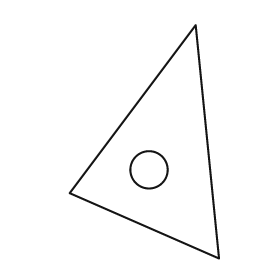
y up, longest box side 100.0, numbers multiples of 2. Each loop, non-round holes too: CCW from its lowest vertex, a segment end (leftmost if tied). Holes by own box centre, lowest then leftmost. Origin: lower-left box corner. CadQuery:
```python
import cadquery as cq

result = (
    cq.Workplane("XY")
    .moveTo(64.0, 0.0)
    .lineTo(54.0, 100.0)
    .lineTo(0.0, 28.0)
    .close()
    .moveTo(34.0, 38.0)
    .circle(8.0)
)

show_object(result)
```